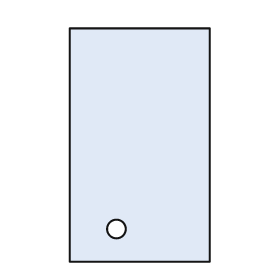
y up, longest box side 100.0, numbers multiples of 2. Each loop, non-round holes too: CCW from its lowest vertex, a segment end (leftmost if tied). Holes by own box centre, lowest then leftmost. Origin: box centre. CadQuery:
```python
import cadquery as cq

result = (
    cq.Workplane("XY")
    .moveTo(-30.0, -50.0)
    .lineTo(30.0, -50.0)
    .lineTo(30.0, 50.0)
    .lineTo(-30.0, 50.0)
    .close()
    .moveTo(-10.0, -36.0)
    .circle(4.0)
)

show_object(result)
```